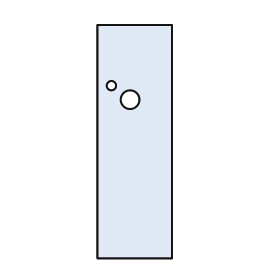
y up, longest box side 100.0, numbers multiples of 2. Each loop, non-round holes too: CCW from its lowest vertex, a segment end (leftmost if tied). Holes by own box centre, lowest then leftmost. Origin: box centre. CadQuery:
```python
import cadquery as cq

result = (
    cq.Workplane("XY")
    .moveTo(-16.0, -50.0)
    .lineTo(16.0, -50.0)
    .lineTo(16.0, 50.0)
    .lineTo(-16.0, 50.0)
    .close()
    .moveTo(-2.0, 18.0)
    .circle(4.0)
    .moveTo(-10.0, 24.0)
    .circle(2.0)
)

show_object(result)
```